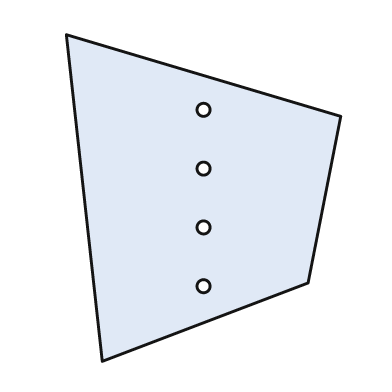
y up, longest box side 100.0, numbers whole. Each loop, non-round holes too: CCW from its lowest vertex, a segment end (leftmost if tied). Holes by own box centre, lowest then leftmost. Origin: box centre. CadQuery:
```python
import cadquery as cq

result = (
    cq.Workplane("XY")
    .moveTo(-31.0, -50.0)
    .lineTo(32.0, -26.0)
    .lineTo(42.0, 25.0)
    .lineTo(-42.0, 50.0)
    .close()
    .moveTo(0.0, -27.0)
    .circle(2.0)
    .moveTo(0.0, -9.0)
    .circle(2.0)
    .moveTo(0.0, 9.0)
    .circle(2.0)
    .moveTo(0.0, 27.0)
    .circle(2.0)
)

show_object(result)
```